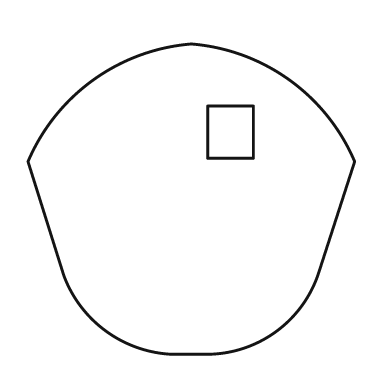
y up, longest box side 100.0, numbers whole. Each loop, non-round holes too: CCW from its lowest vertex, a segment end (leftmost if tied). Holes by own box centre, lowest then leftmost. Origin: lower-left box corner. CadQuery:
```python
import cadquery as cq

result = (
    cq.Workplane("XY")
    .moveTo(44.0, 0.0)
    .lineTo(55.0, 0.0)
    .threePointArc((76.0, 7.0), (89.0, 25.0))
    .lineTo(100.0, 59.0)
    .threePointArc((80.0, 84.0), (50.0, 95.0))
    .threePointArc((20.0, 84.0), (0.0, 59.0))
    .lineTo(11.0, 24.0)
    .threePointArc((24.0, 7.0), (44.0, 0.0))
    .close()
    .moveTo(55.0, 60.0)
    .lineTo(69.0, 60.0)
    .lineTo(69.0, 76.0)
    .lineTo(55.0, 76.0)
    .close()
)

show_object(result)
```